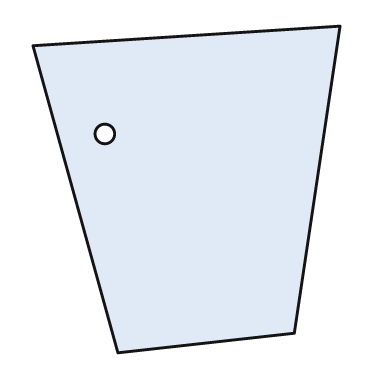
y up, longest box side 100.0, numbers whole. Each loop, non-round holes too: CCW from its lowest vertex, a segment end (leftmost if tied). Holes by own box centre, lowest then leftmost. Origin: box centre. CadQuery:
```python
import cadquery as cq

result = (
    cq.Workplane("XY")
    .moveTo(-21.0, -50.0)
    .lineTo(33.0, -44.0)
    .lineTo(47.0, 50.0)
    .lineTo(-47.0, 44.0)
    .close()
    .moveTo(-25.0, 17.0)
    .circle(3.0)
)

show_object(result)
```